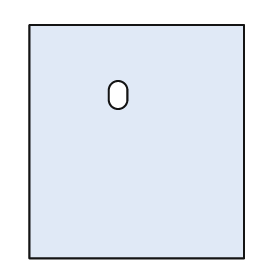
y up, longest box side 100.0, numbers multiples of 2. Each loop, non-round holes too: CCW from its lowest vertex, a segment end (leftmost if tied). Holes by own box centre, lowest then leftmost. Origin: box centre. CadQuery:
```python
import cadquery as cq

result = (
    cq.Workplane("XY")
    .moveTo(-46.0, -50.0)
    .lineTo(46.0, -50.0)
    .lineTo(46.0, 50.0)
    .lineTo(-46.0, 50.0)
    .close()
    .moveTo(-12.0, 18.0)
    .threePointArc((-8.0, 14.0), (-4.0, 18.0))
    .lineTo(-4.0, 22.0)
    .threePointArc((-8.0, 26.0), (-12.0, 22.0))
    .close()
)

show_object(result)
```